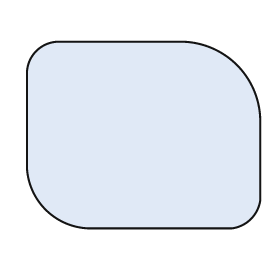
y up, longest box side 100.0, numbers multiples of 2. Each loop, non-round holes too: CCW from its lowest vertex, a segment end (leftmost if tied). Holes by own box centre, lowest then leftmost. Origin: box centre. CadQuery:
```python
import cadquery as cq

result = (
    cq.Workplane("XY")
    .moveTo(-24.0, -40.0)
    .lineTo(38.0, -40.0)
    .threePointArc((46.0, -36.0), (50.0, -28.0))
    .lineTo(50.0, 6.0)
    .threePointArc((40.0, 30.0), (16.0, 40.0))
    .lineTo(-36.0, 40.0)
    .threePointArc((-46.0, 36.0), (-50.0, 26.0))
    .lineTo(-50.0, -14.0)
    .threePointArc((-42.0, -32.0), (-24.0, -40.0))
    .close()
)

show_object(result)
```